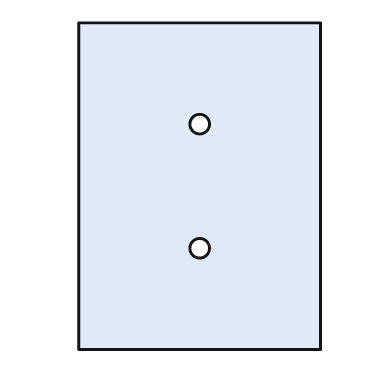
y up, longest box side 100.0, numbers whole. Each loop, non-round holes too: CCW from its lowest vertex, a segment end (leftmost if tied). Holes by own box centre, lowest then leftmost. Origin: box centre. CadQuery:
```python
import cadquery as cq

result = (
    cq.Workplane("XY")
    .moveTo(-37.0, -50.0)
    .lineTo(37.0, -50.0)
    .lineTo(37.0, 50.0)
    .lineTo(-37.0, 50.0)
    .close()
    .moveTo(0.0, -19.0)
    .circle(3.0)
    .moveTo(0.0, 19.0)
    .circle(3.0)
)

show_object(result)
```